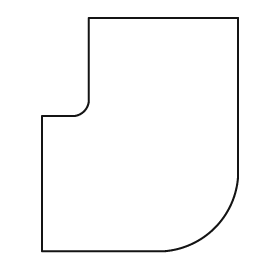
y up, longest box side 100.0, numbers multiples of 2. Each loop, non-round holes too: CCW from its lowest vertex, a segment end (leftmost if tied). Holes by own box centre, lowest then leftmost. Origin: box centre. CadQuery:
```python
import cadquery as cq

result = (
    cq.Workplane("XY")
    .moveTo(-42.0, -50.0)
    .lineTo(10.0, -50.0)
    .threePointArc((32.0, -40.0), (42.0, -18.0))
    .lineTo(42.0, 50.0)
    .lineTo(-22.0, 50.0)
    .lineTo(-22.0, 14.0)
    .threePointArc((-24.0, 10.0), (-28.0, 8.0))
    .lineTo(-42.0, 8.0)
    .close()
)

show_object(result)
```